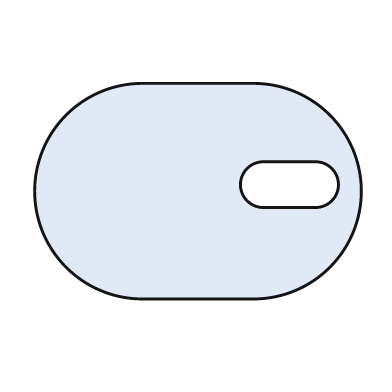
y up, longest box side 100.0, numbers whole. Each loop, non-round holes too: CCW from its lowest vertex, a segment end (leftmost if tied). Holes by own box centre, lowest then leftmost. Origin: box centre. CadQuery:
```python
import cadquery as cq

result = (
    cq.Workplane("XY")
    .moveTo(-17.0, -33.0)
    .lineTo(17.0, -33.0)
    .threePointArc((50.0, 0.0), (17.0, 33.0))
    .lineTo(-17.0, 33.0)
    .threePointArc((-50.0, 0.0), (-17.0, -33.0))
    .close()
    .moveTo(20.0, -5.0)
    .lineTo(36.0, -5.0)
    .threePointArc((43.0, 2.0), (36.0, 9.0))
    .lineTo(20.0, 9.0)
    .threePointArc((13.0, 2.0), (20.0, -5.0))
    .close()
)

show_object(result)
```